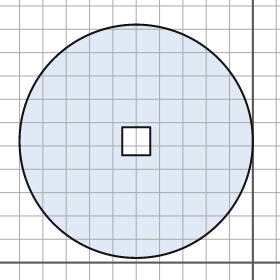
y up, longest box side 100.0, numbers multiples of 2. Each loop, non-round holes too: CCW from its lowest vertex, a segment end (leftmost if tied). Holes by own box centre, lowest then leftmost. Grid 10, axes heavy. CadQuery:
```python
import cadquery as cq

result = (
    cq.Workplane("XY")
    .moveTo(-50.0, 52.0)
    .circle(50.0)
    .moveTo(-56.0, 46.0)
    .lineTo(-44.0, 46.0)
    .lineTo(-44.0, 58.0)
    .lineTo(-56.0, 58.0)
    .close()
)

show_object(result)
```